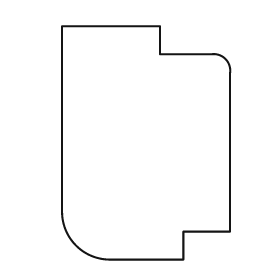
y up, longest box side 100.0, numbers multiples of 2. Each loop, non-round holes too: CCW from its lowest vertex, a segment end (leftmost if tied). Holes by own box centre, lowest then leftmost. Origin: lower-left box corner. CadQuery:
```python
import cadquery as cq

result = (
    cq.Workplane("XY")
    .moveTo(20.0, 0.0)
    .lineTo(52.0, 0.0)
    .lineTo(52.0, 12.0)
    .lineTo(72.0, 12.0)
    .lineTo(72.0, 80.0)
    .threePointArc((70.0, 86.0), (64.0, 88.0))
    .lineTo(42.0, 88.0)
    .lineTo(42.0, 100.0)
    .lineTo(0.0, 100.0)
    .lineTo(0.0, 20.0)
    .threePointArc((6.0, 6.0), (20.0, 0.0))
    .close()
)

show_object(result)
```